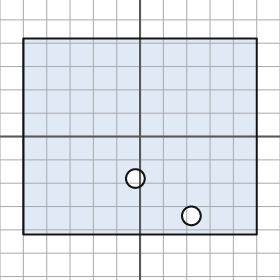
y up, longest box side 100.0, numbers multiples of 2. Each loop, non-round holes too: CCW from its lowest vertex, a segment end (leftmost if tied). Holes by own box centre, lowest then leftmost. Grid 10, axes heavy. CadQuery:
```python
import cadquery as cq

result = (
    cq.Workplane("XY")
    .moveTo(-50.0, -42.0)
    .lineTo(50.0, -42.0)
    .lineTo(50.0, 42.0)
    .lineTo(-50.0, 42.0)
    .close()
    .moveTo(22.0, -34.0)
    .circle(4.0)
    .moveTo(-2.0, -18.0)
    .circle(4.0)
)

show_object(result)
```